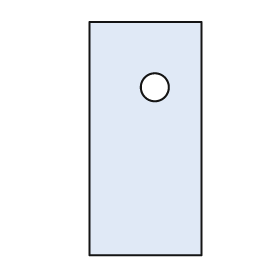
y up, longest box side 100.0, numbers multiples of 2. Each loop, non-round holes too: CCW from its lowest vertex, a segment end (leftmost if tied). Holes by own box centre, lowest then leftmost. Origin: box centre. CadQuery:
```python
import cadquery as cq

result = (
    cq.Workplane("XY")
    .moveTo(-24.0, -50.0)
    .lineTo(24.0, -50.0)
    .lineTo(24.0, 50.0)
    .lineTo(-24.0, 50.0)
    .close()
    .moveTo(4.0, 22.0)
    .circle(6.0)
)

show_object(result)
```